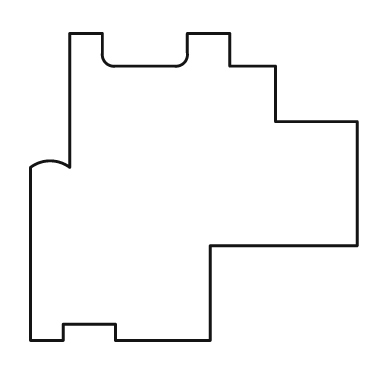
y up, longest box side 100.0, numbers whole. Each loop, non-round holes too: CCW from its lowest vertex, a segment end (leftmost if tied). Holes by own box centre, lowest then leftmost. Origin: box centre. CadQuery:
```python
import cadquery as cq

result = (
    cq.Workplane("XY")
    .moveTo(-50.0, -47.0)
    .lineTo(-40.0, -47.0)
    .lineTo(-40.0, -42.0)
    .lineTo(-24.0, -42.0)
    .lineTo(-24.0, -47.0)
    .lineTo(5.0, -47.0)
    .lineTo(5.0, -18.0)
    .lineTo(50.0, -18.0)
    .lineTo(50.0, 20.0)
    .lineTo(25.0, 20.0)
    .lineTo(25.0, 37.0)
    .lineTo(11.0, 37.0)
    .lineTo(11.0, 47.0)
    .lineTo(-2.0, 47.0)
    .lineTo(-2.0, 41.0)
    .threePointArc((-3.0, 38.0), (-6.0, 37.0))
    .lineTo(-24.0, 37.0)
    .threePointArc((-27.0, 38.0), (-28.0, 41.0))
    .lineTo(-28.0, 47.0)
    .lineTo(-38.0, 47.0)
    .lineTo(-38.0, 6.0)
    .threePointArc((-44.0, 8.0), (-50.0, 6.0))
    .close()
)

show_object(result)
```